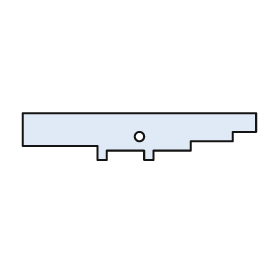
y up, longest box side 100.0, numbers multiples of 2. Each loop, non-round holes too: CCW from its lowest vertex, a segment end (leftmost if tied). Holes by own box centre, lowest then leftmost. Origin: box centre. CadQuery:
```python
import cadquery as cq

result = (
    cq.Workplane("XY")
    .moveTo(-18.0, -10.0)
    .lineTo(-14.0, -10.0)
    .lineTo(-14.0, -6.0)
    .lineTo(2.0, -6.0)
    .lineTo(2.0, -10.0)
    .lineTo(6.0, -10.0)
    .lineTo(6.0, -6.0)
    .lineTo(22.0, -6.0)
    .lineTo(22.0, -2.0)
    .lineTo(40.0, -2.0)
    .lineTo(40.0, 2.0)
    .lineTo(50.0, 2.0)
    .lineTo(50.0, 10.0)
    .lineTo(-50.0, 10.0)
    .lineTo(-50.0, -4.0)
    .lineTo(-18.0, -4.0)
    .close()
    .moveTo(0.0, 0.0)
    .circle(2.0)
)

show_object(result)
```